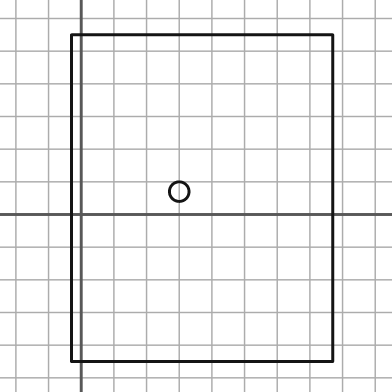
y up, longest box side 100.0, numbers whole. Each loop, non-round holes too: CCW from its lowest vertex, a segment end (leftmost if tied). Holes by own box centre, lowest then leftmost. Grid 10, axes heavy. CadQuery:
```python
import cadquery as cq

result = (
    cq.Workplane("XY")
    .moveTo(-3.0, -45.0)
    .lineTo(77.0, -45.0)
    .lineTo(77.0, 55.0)
    .lineTo(-3.0, 55.0)
    .close()
    .moveTo(30.0, 7.0)
    .circle(3.0)
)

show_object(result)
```